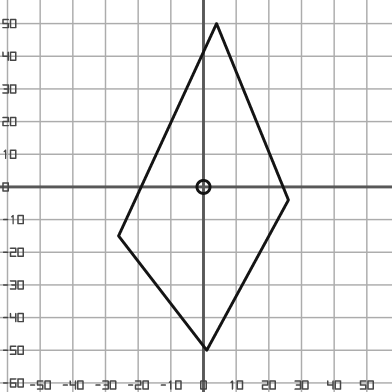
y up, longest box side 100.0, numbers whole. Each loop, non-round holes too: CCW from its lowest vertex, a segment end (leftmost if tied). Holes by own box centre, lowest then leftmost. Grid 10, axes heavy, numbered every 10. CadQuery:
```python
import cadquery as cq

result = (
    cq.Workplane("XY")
    .moveTo(1.0, -50.0)
    .lineTo(26.0, -4.0)
    .lineTo(4.0, 50.0)
    .lineTo(-26.0, -15.0)
    .close()
    .moveTo(0.0, 0.0)
    .circle(2.0)
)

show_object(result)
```